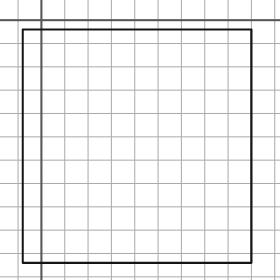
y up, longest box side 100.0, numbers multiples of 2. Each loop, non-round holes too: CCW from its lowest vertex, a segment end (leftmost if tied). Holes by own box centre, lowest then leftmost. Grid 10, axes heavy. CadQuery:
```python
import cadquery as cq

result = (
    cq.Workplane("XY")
    .moveTo(-8.0, -104.0)
    .lineTo(90.0, -104.0)
    .lineTo(90.0, -4.0)
    .lineTo(-8.0, -4.0)
    .close()
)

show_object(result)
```